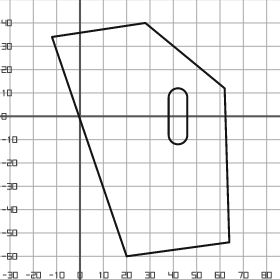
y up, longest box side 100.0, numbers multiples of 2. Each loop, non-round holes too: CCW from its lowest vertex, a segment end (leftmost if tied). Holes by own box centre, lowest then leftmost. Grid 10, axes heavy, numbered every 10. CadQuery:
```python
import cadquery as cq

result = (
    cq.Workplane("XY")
    .moveTo(20.0, -60.0)
    .lineTo(64.0, -54.0)
    .lineTo(62.0, 12.0)
    .lineTo(28.0, 40.0)
    .lineTo(-12.0, 34.0)
    .close()
    .moveTo(38.0, -8.0)
    .threePointArc((42.0, -12.0), (46.0, -8.0))
    .lineTo(46.0, 8.0)
    .threePointArc((42.0, 12.0), (38.0, 8.0))
    .close()
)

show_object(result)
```